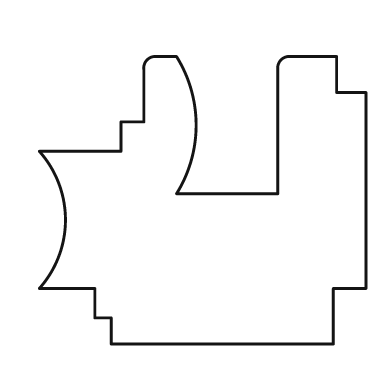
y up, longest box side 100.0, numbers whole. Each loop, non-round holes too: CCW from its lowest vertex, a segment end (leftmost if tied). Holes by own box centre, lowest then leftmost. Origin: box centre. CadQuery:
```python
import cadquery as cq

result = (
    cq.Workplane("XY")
    .moveTo(-28.0, -44.0)
    .lineTo(40.0, -44.0)
    .lineTo(40.0, -27.0)
    .lineTo(50.0, -27.0)
    .lineTo(50.0, 33.0)
    .lineTo(41.0, 33.0)
    .lineTo(41.0, 44.0)
    .lineTo(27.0, 44.0)
    .threePointArc((24.0, 43.0), (23.0, 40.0))
    .lineTo(23.0, 2.0)
    .lineTo(-8.0, 2.0)
    .threePointArc((-2.0, 23.0), (-8.0, 44.0))
    .lineTo(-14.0, 44.0)
    .threePointArc((-17.0, 43.0), (-18.0, 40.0))
    .lineTo(-18.0, 24.0)
    .lineTo(-25.0, 24.0)
    .lineTo(-25.0, 15.0)
    .lineTo(-50.0, 15.0)
    .threePointArc((-42.0, -6.0), (-50.0, -27.0))
    .lineTo(-33.0, -27.0)
    .lineTo(-33.0, -36.0)
    .lineTo(-28.0, -36.0)
    .close()
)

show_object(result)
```